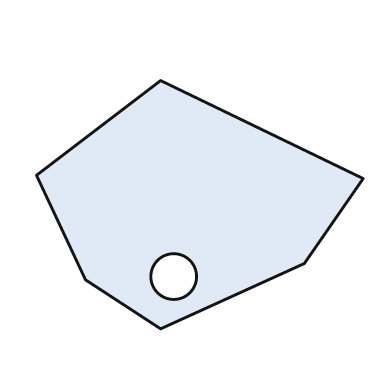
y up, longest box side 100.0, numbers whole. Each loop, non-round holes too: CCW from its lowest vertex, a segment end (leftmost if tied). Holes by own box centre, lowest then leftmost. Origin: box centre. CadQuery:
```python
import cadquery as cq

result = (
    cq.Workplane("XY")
    .moveTo(-12.0, -38.0)
    .lineTo(32.0, -18.0)
    .lineTo(50.0, 8.0)
    .lineTo(-12.0, 38.0)
    .lineTo(-50.0, 9.0)
    .lineTo(-35.0, -23.0)
    .close()
    .moveTo(-8.0, -22.0)
    .circle(7.0)
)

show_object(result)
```